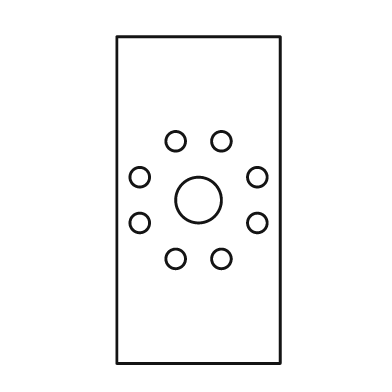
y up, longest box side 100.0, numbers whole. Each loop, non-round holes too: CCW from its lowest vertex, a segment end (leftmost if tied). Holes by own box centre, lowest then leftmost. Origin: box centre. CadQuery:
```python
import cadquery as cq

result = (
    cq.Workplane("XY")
    .moveTo(-25.0, -50.0)
    .lineTo(25.0, -50.0)
    .lineTo(25.0, 50.0)
    .lineTo(-25.0, 50.0)
    .close()
    .moveTo(-7.0, -18.0)
    .circle(3.0)
    .moveTo(7.0, -18.0)
    .circle(3.0)
    .moveTo(-18.0, -7.0)
    .circle(3.0)
    .moveTo(18.0, -7.0)
    .circle(3.0)
    .moveTo(0.0, 0.0)
    .circle(7.0)
    .moveTo(-18.0, 7.0)
    .circle(3.0)
    .moveTo(18.0, 7.0)
    .circle(3.0)
    .moveTo(-7.0, 18.0)
    .circle(3.0)
    .moveTo(7.0, 18.0)
    .circle(3.0)
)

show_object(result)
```